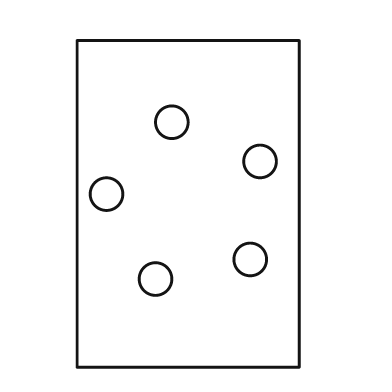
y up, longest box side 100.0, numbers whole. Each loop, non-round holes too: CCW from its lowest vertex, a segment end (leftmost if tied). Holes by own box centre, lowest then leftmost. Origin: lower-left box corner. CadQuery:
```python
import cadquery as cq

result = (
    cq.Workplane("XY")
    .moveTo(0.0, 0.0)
    .lineTo(68.0, 0.0)
    .lineTo(68.0, 100.0)
    .lineTo(0.0, 100.0)
    .close()
    .moveTo(24.0, 27.0)
    .circle(5.0)
    .moveTo(53.0, 33.0)
    .circle(5.0)
    .moveTo(9.0, 53.0)
    .circle(5.0)
    .moveTo(56.0, 63.0)
    .circle(5.0)
    .moveTo(29.0, 75.0)
    .circle(5.0)
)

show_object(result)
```